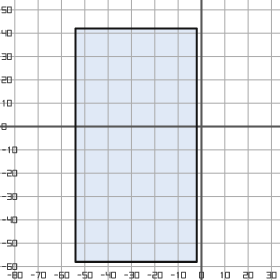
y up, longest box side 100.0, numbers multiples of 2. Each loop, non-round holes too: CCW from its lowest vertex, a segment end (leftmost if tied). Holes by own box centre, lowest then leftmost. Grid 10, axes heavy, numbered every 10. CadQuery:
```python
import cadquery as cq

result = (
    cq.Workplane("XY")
    .moveTo(-54.0, -58.0)
    .lineTo(-2.0, -58.0)
    .lineTo(-2.0, 42.0)
    .lineTo(-54.0, 42.0)
    .close()
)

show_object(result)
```